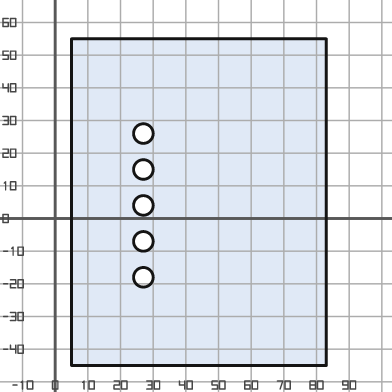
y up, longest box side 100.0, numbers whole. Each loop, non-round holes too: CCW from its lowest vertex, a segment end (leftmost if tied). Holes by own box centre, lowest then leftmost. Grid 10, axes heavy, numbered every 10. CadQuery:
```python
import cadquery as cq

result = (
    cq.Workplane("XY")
    .moveTo(5.0, -45.0)
    .lineTo(83.0, -45.0)
    .lineTo(83.0, 55.0)
    .lineTo(5.0, 55.0)
    .close()
    .moveTo(27.0, -18.0)
    .circle(3.0)
    .moveTo(27.0, -7.0)
    .circle(3.0)
    .moveTo(27.0, 4.0)
    .circle(3.0)
    .moveTo(27.0, 15.0)
    .circle(3.0)
    .moveTo(27.0, 26.0)
    .circle(3.0)
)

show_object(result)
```